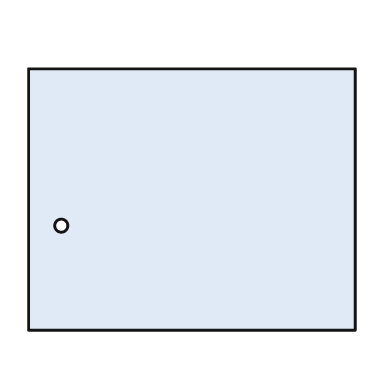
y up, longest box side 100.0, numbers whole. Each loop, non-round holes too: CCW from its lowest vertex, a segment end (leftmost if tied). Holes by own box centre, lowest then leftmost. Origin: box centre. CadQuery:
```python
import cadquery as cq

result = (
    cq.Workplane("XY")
    .moveTo(-50.0, -40.0)
    .lineTo(50.0, -40.0)
    .lineTo(50.0, 40.0)
    .lineTo(-50.0, 40.0)
    .close()
    .moveTo(-40.0, -8.0)
    .circle(2.0)
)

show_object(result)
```